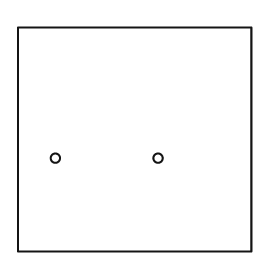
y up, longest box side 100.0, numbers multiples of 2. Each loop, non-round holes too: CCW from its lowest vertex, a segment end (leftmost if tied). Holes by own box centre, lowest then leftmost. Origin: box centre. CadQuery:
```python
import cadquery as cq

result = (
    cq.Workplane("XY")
    .moveTo(-50.0, -48.0)
    .lineTo(50.0, -48.0)
    .lineTo(50.0, 48.0)
    .lineTo(-50.0, 48.0)
    .close()
    .moveTo(-34.0, -8.0)
    .circle(2.0)
    .moveTo(10.0, -8.0)
    .circle(2.0)
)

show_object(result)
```